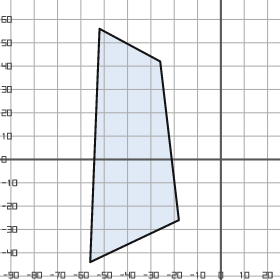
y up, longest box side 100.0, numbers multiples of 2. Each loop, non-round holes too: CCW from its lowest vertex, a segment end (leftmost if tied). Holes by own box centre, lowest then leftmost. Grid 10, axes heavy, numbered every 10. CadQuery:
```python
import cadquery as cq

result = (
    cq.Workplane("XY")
    .moveTo(-56.0, -44.0)
    .lineTo(-18.0, -26.0)
    .lineTo(-26.0, 42.0)
    .lineTo(-52.0, 56.0)
    .close()
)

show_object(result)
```